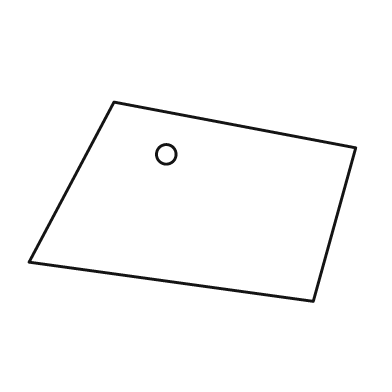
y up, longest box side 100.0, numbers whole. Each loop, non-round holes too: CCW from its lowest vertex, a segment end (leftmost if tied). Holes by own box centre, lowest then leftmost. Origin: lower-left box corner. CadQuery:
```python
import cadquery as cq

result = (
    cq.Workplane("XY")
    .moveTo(87.0, 0.0)
    .lineTo(100.0, 47.0)
    .lineTo(26.0, 61.0)
    .lineTo(0.0, 12.0)
    .close()
    .moveTo(42.0, 45.0)
    .circle(3.0)
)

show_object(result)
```